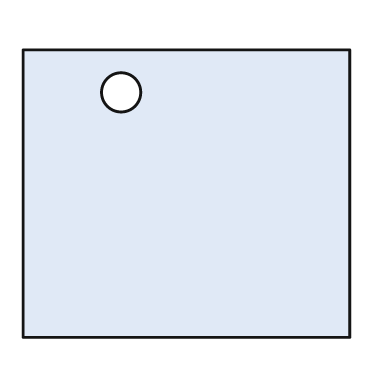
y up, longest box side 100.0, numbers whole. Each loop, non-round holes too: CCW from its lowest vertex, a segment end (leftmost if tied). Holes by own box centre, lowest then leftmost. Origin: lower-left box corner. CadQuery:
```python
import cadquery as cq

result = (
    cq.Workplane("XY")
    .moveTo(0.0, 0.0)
    .lineTo(100.0, 0.0)
    .lineTo(100.0, 88.0)
    .lineTo(0.0, 88.0)
    .close()
    .moveTo(30.0, 75.0)
    .circle(6.0)
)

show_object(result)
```